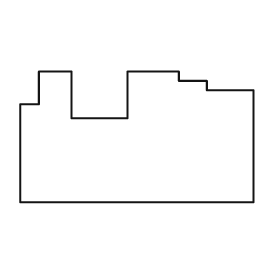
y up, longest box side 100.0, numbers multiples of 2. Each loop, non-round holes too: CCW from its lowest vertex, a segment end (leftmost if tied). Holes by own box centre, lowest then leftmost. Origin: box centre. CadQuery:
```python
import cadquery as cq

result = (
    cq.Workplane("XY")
    .moveTo(-50.0, -28.0)
    .lineTo(50.0, -28.0)
    .lineTo(50.0, 20.0)
    .lineTo(30.0, 20.0)
    .lineTo(30.0, 24.0)
    .lineTo(18.0, 24.0)
    .lineTo(18.0, 28.0)
    .lineTo(-4.0, 28.0)
    .lineTo(-4.0, 8.0)
    .lineTo(-28.0, 8.0)
    .lineTo(-28.0, 28.0)
    .lineTo(-42.0, 28.0)
    .lineTo(-42.0, 14.0)
    .lineTo(-50.0, 14.0)
    .close()
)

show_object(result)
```